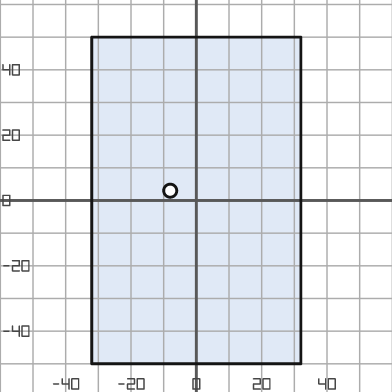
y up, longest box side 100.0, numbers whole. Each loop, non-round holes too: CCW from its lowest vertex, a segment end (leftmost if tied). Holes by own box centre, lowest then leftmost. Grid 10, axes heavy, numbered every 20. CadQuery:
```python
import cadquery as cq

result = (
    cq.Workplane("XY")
    .moveTo(-32.0, -50.0)
    .lineTo(32.0, -50.0)
    .lineTo(32.0, 50.0)
    .lineTo(-32.0, 50.0)
    .close()
    .moveTo(-8.0, 3.0)
    .circle(2.0)
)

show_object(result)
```